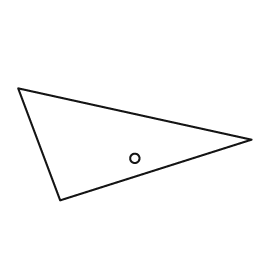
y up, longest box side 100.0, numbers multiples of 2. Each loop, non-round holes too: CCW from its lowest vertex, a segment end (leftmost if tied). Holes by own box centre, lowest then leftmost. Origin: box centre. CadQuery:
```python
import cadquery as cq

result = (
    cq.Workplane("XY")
    .moveTo(-32.0, -24.0)
    .lineTo(50.0, 2.0)
    .lineTo(-50.0, 24.0)
    .close()
    .moveTo(0.0, -6.0)
    .circle(2.0)
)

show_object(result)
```